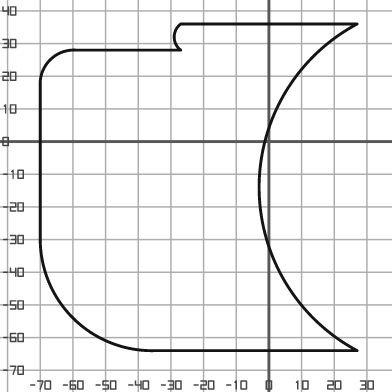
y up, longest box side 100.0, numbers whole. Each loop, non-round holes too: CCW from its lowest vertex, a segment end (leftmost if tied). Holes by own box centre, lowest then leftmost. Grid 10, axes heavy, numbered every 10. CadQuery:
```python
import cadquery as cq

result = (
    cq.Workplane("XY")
    .moveTo(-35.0, -64.0)
    .lineTo(27.0, -64.0)
    .threePointArc((-3.0, -14.0), (27.0, 36.0))
    .lineTo(-27.0, 36.0)
    .threePointArc((-29.0, 32.0), (-27.0, 28.0))
    .lineTo(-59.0, 28.0)
    .threePointArc((-67.0, 25.0), (-70.0, 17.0))
    .lineTo(-70.0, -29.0)
    .threePointArc((-60.0, -54.0), (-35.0, -64.0))
    .close()
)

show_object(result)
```